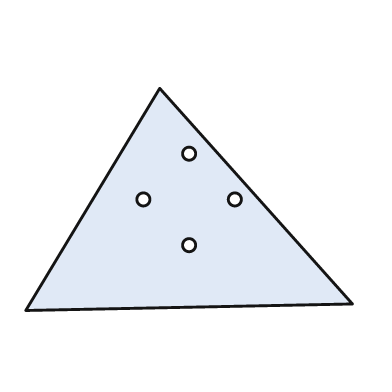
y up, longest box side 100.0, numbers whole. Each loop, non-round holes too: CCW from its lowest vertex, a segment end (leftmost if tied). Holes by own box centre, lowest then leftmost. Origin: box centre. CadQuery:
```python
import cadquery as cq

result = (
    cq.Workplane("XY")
    .moveTo(-50.0, -34.0)
    .lineTo(50.0, -32.0)
    .lineTo(-9.0, 34.0)
    .close()
    .moveTo(0.0, -14.0)
    .circle(2.0)
    .moveTo(-14.0, 0.0)
    .circle(2.0)
    .moveTo(14.0, 0.0)
    .circle(2.0)
    .moveTo(0.0, 14.0)
    .circle(2.0)
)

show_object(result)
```